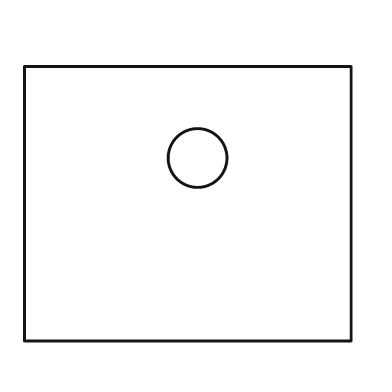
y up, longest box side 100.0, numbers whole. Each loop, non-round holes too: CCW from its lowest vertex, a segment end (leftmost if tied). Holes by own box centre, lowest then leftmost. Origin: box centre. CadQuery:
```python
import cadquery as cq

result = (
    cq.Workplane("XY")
    .moveTo(-50.0, -42.0)
    .lineTo(50.0, -42.0)
    .lineTo(50.0, 42.0)
    .lineTo(-50.0, 42.0)
    .close()
    .moveTo(3.0, 14.0)
    .circle(9.0)
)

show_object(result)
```